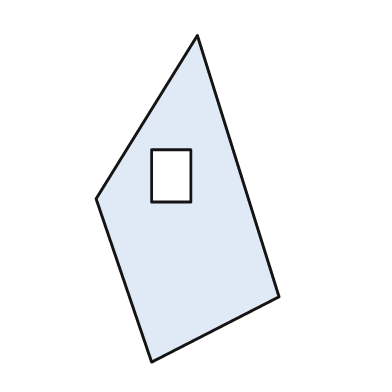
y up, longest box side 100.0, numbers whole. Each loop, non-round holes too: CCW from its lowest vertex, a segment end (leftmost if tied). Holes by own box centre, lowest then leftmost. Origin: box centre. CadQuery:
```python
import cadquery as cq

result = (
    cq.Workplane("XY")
    .moveTo(-11.0, -50.0)
    .lineTo(28.0, -30.0)
    .lineTo(3.0, 50.0)
    .lineTo(-28.0, 0.0)
    .close()
    .moveTo(-11.0, -1.0)
    .lineTo(1.0, -1.0)
    .lineTo(1.0, 15.0)
    .lineTo(-11.0, 15.0)
    .close()
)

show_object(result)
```